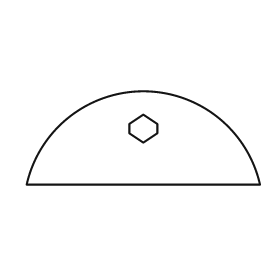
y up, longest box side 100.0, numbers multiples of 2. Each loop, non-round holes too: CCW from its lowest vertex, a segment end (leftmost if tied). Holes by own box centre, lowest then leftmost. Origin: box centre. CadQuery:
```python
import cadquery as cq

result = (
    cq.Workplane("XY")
    .moveTo(-50.0, -20.0)
    .lineTo(50.0, -20.0)
    .threePointArc((0.0, 20.0), (-50.0, -20.0))
    .close()
    .moveTo(0.0, -2.0)
    .lineTo(6.0, 2.0)
    .lineTo(6.0, 6.0)
    .lineTo(0.0, 10.0)
    .lineTo(-6.0, 6.0)
    .lineTo(-6.0, 2.0)
    .close()
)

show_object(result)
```